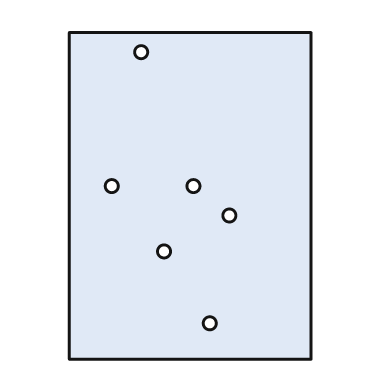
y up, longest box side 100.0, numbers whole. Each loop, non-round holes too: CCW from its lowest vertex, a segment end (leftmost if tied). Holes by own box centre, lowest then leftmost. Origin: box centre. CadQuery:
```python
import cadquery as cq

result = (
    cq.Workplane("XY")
    .moveTo(-37.0, -50.0)
    .lineTo(37.0, -50.0)
    .lineTo(37.0, 50.0)
    .lineTo(-37.0, 50.0)
    .close()
    .moveTo(6.0, -39.0)
    .circle(2.0)
    .moveTo(-8.0, -17.0)
    .circle(2.0)
    .moveTo(12.0, -6.0)
    .circle(2.0)
    .moveTo(-24.0, 3.0)
    .circle(2.0)
    .moveTo(1.0, 3.0)
    .circle(2.0)
    .moveTo(-15.0, 44.0)
    .circle(2.0)
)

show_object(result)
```